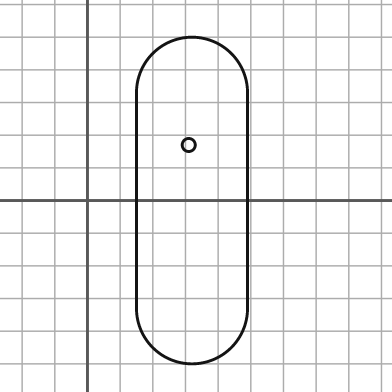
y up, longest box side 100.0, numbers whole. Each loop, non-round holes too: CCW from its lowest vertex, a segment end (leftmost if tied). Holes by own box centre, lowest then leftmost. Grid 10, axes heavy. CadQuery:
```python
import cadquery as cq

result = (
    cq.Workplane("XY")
    .moveTo(15.0, -33.0)
    .threePointArc((32.0, -50.0), (49.0, -33.0))
    .lineTo(49.0, 33.0)
    .threePointArc((32.0, 50.0), (15.0, 33.0))
    .close()
    .moveTo(31.0, 17.0)
    .circle(2.0)
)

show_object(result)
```